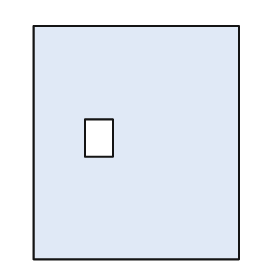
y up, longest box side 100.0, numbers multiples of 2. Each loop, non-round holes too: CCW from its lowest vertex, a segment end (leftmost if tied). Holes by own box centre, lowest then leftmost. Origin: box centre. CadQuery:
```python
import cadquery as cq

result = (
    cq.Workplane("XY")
    .moveTo(-44.0, -50.0)
    .lineTo(44.0, -50.0)
    .lineTo(44.0, 50.0)
    .lineTo(-44.0, 50.0)
    .close()
    .moveTo(-22.0, -6.0)
    .lineTo(-10.0, -6.0)
    .lineTo(-10.0, 10.0)
    .lineTo(-22.0, 10.0)
    .close()
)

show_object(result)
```